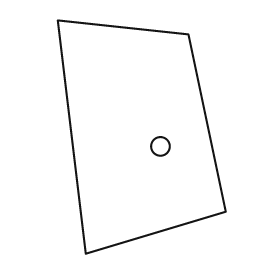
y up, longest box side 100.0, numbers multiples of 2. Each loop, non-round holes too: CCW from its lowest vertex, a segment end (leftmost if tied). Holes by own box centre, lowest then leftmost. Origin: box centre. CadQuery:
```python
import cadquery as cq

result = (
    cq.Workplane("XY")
    .moveTo(-24.0, -50.0)
    .lineTo(36.0, -32.0)
    .lineTo(20.0, 44.0)
    .lineTo(-36.0, 50.0)
    .close()
    .moveTo(8.0, -4.0)
    .circle(4.0)
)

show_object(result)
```